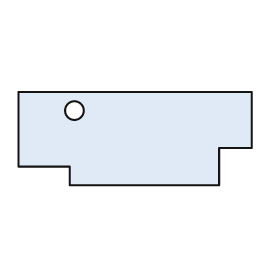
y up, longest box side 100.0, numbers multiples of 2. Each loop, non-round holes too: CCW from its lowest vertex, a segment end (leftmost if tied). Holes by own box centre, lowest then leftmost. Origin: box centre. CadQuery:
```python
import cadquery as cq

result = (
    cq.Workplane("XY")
    .moveTo(-28.0, -20.0)
    .lineTo(36.0, -20.0)
    .lineTo(36.0, -4.0)
    .lineTo(50.0, -4.0)
    .lineTo(50.0, 20.0)
    .lineTo(-50.0, 20.0)
    .lineTo(-50.0, -12.0)
    .lineTo(-28.0, -12.0)
    .close()
    .moveTo(-26.0, 12.0)
    .circle(4.0)
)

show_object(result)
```